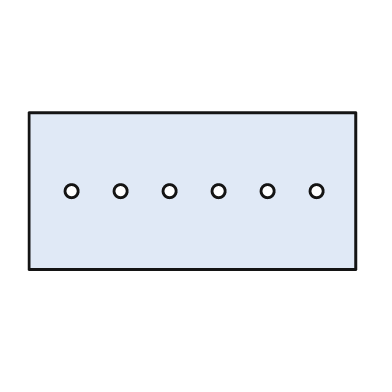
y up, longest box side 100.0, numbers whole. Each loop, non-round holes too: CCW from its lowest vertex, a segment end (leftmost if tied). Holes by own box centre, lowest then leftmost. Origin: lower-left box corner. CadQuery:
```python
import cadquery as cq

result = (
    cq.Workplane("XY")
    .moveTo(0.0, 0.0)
    .lineTo(100.0, 0.0)
    .lineTo(100.0, 48.0)
    .lineTo(0.0, 48.0)
    .close()
    .moveTo(13.0, 24.0)
    .circle(2.0)
    .moveTo(28.0, 24.0)
    .circle(2.0)
    .moveTo(43.0, 24.0)
    .circle(2.0)
    .moveTo(58.0, 24.0)
    .circle(2.0)
    .moveTo(73.0, 24.0)
    .circle(2.0)
    .moveTo(88.0, 24.0)
    .circle(2.0)
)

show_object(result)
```